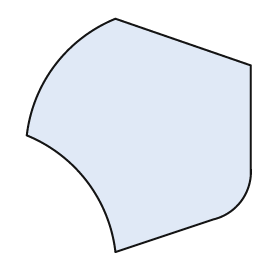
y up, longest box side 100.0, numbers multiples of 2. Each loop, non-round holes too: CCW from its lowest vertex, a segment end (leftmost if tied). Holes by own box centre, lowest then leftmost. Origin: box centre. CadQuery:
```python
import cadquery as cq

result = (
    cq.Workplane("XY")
    .moveTo(-10.0, -50.0)
    .lineTo(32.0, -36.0)
    .threePointArc((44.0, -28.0), (48.0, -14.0))
    .lineTo(48.0, 30.0)
    .lineTo(-10.0, 50.0)
    .threePointArc((-36.0, 30.0), (-48.0, 0.0))
    .threePointArc((-22.0, -20.0), (-10.0, -50.0))
    .close()
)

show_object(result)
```